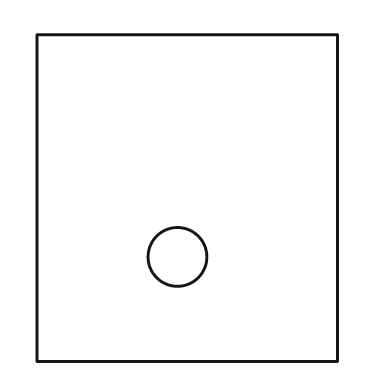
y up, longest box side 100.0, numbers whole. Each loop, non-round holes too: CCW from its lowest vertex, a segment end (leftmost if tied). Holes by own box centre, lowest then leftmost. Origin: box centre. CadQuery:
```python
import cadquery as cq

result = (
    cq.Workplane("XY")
    .moveTo(-46.0, -50.0)
    .lineTo(46.0, -50.0)
    .lineTo(46.0, 50.0)
    .lineTo(-46.0, 50.0)
    .close()
    .moveTo(-3.0, -18.0)
    .circle(9.0)
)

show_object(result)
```